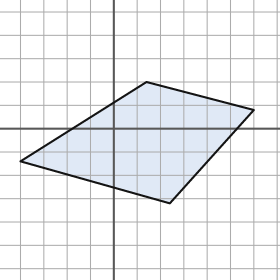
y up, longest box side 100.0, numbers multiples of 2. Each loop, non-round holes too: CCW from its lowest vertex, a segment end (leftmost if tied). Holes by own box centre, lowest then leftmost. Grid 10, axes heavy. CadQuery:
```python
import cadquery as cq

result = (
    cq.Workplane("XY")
    .moveTo(24.0, -32.0)
    .lineTo(60.0, 8.0)
    .lineTo(14.0, 20.0)
    .lineTo(-40.0, -14.0)
    .close()
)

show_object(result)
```